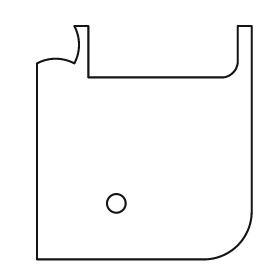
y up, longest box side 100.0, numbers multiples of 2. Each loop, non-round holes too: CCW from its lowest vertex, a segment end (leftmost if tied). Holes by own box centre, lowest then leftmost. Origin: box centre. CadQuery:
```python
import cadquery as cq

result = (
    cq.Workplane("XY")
    .moveTo(-46.0, -50.0)
    .lineTo(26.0, -50.0)
    .threePointArc((40.0, -44.0), (46.0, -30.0))
    .lineTo(46.0, 50.0)
    .lineTo(40.0, 50.0)
    .lineTo(40.0, 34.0)
    .threePointArc((38.0, 30.0), (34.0, 28.0))
    .lineTo(-24.0, 28.0)
    .lineTo(-24.0, 50.0)
    .lineTo(-30.0, 50.0)
    .threePointArc((-28.0, 42.0), (-30.0, 34.0))
    .threePointArc((-38.0, 36.0), (-46.0, 34.0))
    .close()
    .moveTo(-12.0, -26.0)
    .circle(4.0)
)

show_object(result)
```